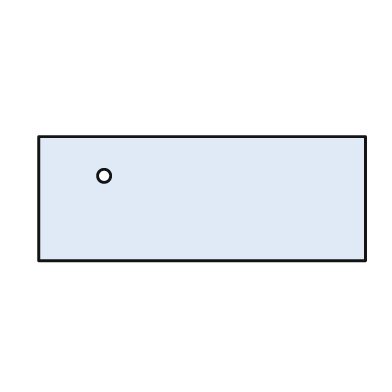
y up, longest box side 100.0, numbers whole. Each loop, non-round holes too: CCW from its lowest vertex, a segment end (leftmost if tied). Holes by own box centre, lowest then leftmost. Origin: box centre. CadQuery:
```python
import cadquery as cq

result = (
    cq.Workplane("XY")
    .moveTo(-50.0, -19.0)
    .lineTo(50.0, -19.0)
    .lineTo(50.0, 19.0)
    .lineTo(-50.0, 19.0)
    .close()
    .moveTo(-30.0, 7.0)
    .circle(2.0)
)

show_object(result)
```